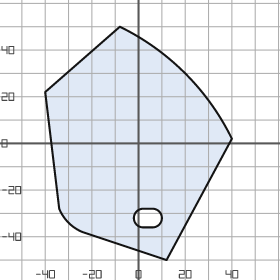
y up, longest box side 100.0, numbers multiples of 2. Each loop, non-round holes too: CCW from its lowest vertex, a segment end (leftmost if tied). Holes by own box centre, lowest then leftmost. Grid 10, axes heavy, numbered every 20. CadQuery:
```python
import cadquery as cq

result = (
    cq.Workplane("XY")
    .moveTo(12.0, -50.0)
    .lineTo(40.0, 2.0)
    .threePointArc((20.0, 30.0), (-8.0, 50.0))
    .lineTo(-40.0, 22.0)
    .lineTo(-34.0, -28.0)
    .threePointArc((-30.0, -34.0), (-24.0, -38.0))
    .close()
    .moveTo(2.0, -36.0)
    .lineTo(6.0, -36.0)
    .threePointArc((10.0, -32.0), (6.0, -28.0))
    .lineTo(2.0, -28.0)
    .threePointArc((-2.0, -32.0), (2.0, -36.0))
    .close()
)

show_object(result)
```